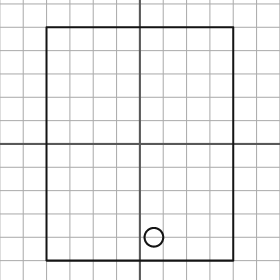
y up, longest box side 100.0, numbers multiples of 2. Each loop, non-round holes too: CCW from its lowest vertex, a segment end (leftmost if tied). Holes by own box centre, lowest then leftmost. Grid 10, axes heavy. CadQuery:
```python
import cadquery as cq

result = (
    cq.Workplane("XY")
    .moveTo(-40.0, -50.0)
    .lineTo(40.0, -50.0)
    .lineTo(40.0, 50.0)
    .lineTo(-40.0, 50.0)
    .close()
    .moveTo(6.0, -40.0)
    .circle(4.0)
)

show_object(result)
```